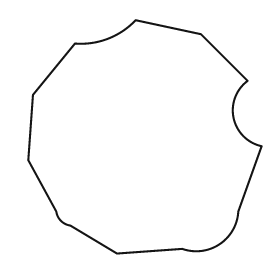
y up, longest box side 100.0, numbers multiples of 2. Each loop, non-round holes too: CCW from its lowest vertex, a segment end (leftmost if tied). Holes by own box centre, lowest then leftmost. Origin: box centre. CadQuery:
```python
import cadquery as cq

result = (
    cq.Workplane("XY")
    .moveTo(-12.0, -50.0)
    .lineTo(16.0, -48.0)
    .threePointArc((32.0, -46.0), (40.0, -32.0))
    .lineTo(50.0, -4.0)
    .threePointArc((38.0, 8.0), (44.0, 24.0))
    .lineTo(24.0, 44.0)
    .lineTo(-4.0, 50.0)
    .threePointArc((-16.0, 42.0), (-30.0, 40.0))
    .lineTo(-48.0, 18.0)
    .lineTo(-50.0, -10.0)
    .lineTo(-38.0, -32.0)
    .threePointArc((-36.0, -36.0), (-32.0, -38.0))
    .close()
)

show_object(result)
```